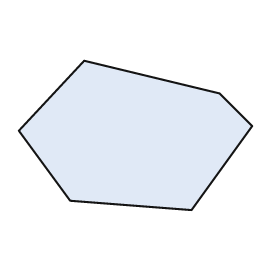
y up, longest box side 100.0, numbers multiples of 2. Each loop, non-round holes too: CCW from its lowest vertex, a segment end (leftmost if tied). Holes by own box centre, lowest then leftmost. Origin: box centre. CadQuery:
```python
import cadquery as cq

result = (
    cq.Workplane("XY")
    .moveTo(24.0, -32.0)
    .lineTo(50.0, 4.0)
    .lineTo(36.0, 18.0)
    .lineTo(-22.0, 32.0)
    .lineTo(-50.0, 2.0)
    .lineTo(-28.0, -28.0)
    .close()
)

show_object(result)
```